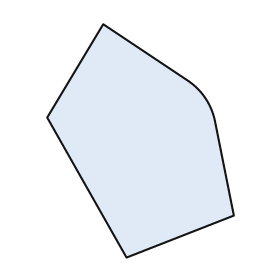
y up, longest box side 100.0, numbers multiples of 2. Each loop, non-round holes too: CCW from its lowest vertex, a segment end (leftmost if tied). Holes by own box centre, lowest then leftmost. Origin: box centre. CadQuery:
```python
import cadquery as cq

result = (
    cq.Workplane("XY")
    .moveTo(-6.0, -50.0)
    .lineTo(40.0, -32.0)
    .lineTo(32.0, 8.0)
    .threePointArc((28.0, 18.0), (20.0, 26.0))
    .lineTo(-16.0, 50.0)
    .lineTo(-40.0, 10.0)
    .close()
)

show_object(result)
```